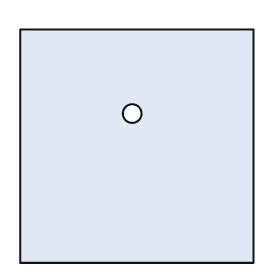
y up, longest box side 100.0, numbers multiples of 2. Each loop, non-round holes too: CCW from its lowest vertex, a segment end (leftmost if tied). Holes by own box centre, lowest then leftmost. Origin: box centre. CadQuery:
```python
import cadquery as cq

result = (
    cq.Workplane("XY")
    .moveTo(-50.0, -50.0)
    .lineTo(50.0, -50.0)
    .lineTo(50.0, 50.0)
    .lineTo(-50.0, 50.0)
    .close()
    .moveTo(-2.0, 14.0)
    .circle(4.0)
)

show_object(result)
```